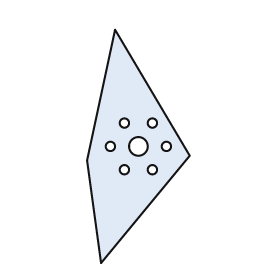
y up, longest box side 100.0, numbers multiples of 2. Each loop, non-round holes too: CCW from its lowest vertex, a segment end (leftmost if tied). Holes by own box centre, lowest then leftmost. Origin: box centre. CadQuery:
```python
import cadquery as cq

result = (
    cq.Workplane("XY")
    .moveTo(-16.0, -50.0)
    .lineTo(22.0, -4.0)
    .lineTo(-10.0, 50.0)
    .lineTo(-22.0, -6.0)
    .close()
    .moveTo(-6.0, -10.0)
    .circle(2.0)
    .moveTo(6.0, -10.0)
    .circle(2.0)
    .moveTo(-12.0, 0.0)
    .circle(2.0)
    .moveTo(0.0, 0.0)
    .circle(4.0)
    .moveTo(12.0, 0.0)
    .circle(2.0)
    .moveTo(-6.0, 10.0)
    .circle(2.0)
    .moveTo(6.0, 10.0)
    .circle(2.0)
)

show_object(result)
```